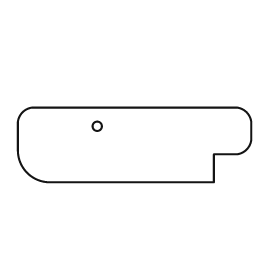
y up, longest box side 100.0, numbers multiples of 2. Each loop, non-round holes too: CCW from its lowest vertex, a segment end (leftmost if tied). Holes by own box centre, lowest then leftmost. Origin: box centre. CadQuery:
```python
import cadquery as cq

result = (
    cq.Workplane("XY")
    .moveTo(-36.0, -16.0)
    .lineTo(34.0, -16.0)
    .lineTo(34.0, -4.0)
    .lineTo(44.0, -4.0)
    .threePointArc((48.0, -2.0), (50.0, 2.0))
    .lineTo(50.0, 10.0)
    .threePointArc((48.0, 14.0), (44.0, 16.0))
    .lineTo(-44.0, 16.0)
    .threePointArc((-48.0, 14.0), (-50.0, 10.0))
    .lineTo(-50.0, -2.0)
    .threePointArc((-46.0, -12.0), (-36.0, -16.0))
    .close()
    .moveTo(-16.0, 8.0)
    .circle(2.0)
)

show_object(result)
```